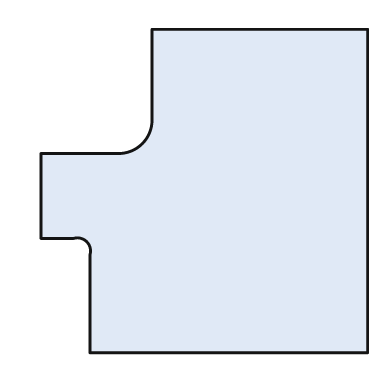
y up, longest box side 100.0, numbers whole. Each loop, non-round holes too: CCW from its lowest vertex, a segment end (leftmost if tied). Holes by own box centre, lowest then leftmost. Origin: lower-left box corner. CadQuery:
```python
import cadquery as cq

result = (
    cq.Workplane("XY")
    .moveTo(15.0, 0.0)
    .lineTo(100.0, 0.0)
    .lineTo(100.0, 99.0)
    .lineTo(34.0, 99.0)
    .lineTo(34.0, 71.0)
    .threePointArc((31.0, 64.0), (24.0, 61.0))
    .lineTo(0.0, 61.0)
    .lineTo(0.0, 35.0)
    .lineTo(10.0, 35.0)
    .threePointArc((14.0, 34.0), (15.0, 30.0))
    .close()
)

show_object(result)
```